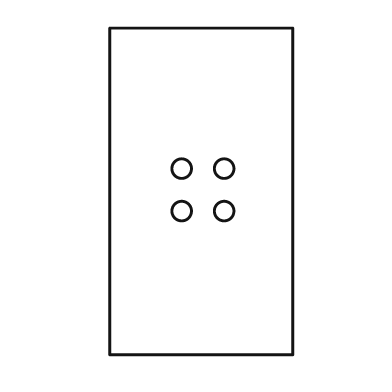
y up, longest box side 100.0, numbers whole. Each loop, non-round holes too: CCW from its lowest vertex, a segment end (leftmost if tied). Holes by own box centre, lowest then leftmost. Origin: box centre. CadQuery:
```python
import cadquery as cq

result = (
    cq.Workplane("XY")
    .moveTo(-28.0, -50.0)
    .lineTo(28.0, -50.0)
    .lineTo(28.0, 50.0)
    .lineTo(-28.0, 50.0)
    .close()
    .moveTo(-6.0, -6.0)
    .circle(3.0)
    .moveTo(7.0, -6.0)
    .circle(3.0)
    .moveTo(-6.0, 7.0)
    .circle(3.0)
    .moveTo(7.0, 7.0)
    .circle(3.0)
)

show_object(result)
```